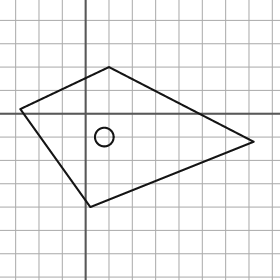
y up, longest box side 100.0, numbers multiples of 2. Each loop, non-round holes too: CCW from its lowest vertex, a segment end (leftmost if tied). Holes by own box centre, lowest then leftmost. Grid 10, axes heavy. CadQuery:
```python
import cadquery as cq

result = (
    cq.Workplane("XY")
    .moveTo(2.0, -40.0)
    .lineTo(72.0, -12.0)
    .lineTo(10.0, 20.0)
    .lineTo(-28.0, 2.0)
    .close()
    .moveTo(8.0, -10.0)
    .circle(4.0)
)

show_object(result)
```